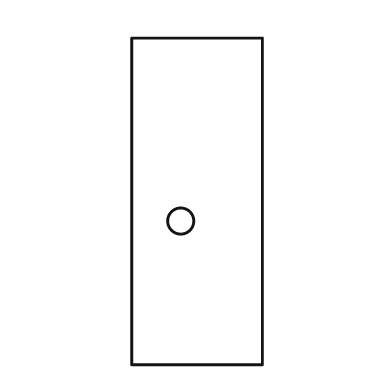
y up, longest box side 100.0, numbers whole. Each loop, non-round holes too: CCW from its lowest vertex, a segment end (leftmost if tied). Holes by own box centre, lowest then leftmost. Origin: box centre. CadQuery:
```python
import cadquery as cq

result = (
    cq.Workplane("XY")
    .moveTo(-20.0, -50.0)
    .lineTo(20.0, -50.0)
    .lineTo(20.0, 50.0)
    .lineTo(-20.0, 50.0)
    .close()
    .moveTo(-5.0, -6.0)
    .circle(4.0)
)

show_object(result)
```